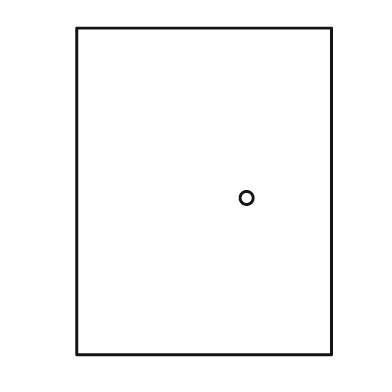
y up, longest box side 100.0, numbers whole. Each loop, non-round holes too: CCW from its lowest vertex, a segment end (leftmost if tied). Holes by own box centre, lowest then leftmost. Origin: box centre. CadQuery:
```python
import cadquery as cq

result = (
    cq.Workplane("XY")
    .moveTo(-39.0, -50.0)
    .lineTo(39.0, -50.0)
    .lineTo(39.0, 50.0)
    .lineTo(-39.0, 50.0)
    .close()
    .moveTo(13.0, -2.0)
    .circle(2.0)
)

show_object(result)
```